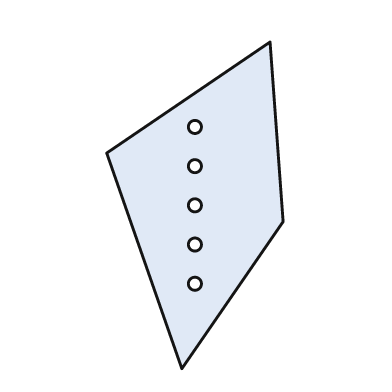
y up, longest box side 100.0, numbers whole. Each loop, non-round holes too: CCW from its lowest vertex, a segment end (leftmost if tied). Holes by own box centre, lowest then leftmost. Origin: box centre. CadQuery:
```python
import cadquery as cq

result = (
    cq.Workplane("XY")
    .moveTo(-4.0, -50.0)
    .lineTo(27.0, -5.0)
    .lineTo(23.0, 50.0)
    .lineTo(-27.0, 16.0)
    .close()
    .moveTo(0.0, -24.0)
    .circle(2.0)
    .moveTo(0.0, -12.0)
    .circle(2.0)
    .moveTo(0.0, 0.0)
    .circle(2.0)
    .moveTo(0.0, 12.0)
    .circle(2.0)
    .moveTo(0.0, 24.0)
    .circle(2.0)
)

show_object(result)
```